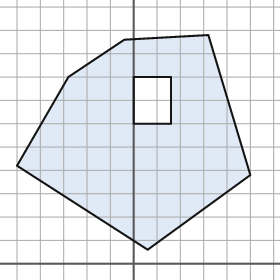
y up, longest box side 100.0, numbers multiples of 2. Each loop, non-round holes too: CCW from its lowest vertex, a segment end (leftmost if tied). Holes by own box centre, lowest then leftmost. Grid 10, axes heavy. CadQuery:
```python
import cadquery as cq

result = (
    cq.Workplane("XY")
    .moveTo(6.0, 6.0)
    .lineTo(50.0, 38.0)
    .lineTo(32.0, 98.0)
    .lineTo(-4.0, 96.0)
    .lineTo(-28.0, 80.0)
    .lineTo(-50.0, 42.0)
    .close()
    .moveTo(0.0, 60.0)
    .lineTo(16.0, 60.0)
    .lineTo(16.0, 80.0)
    .lineTo(0.0, 80.0)
    .close()
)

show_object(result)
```